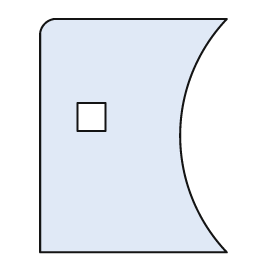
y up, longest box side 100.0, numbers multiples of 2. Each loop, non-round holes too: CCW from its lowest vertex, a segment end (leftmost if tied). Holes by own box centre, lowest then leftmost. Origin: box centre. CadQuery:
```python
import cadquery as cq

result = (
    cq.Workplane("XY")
    .moveTo(-40.0, -50.0)
    .lineTo(40.0, -50.0)
    .threePointArc((20.0, 0.0), (40.0, 50.0))
    .lineTo(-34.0, 50.0)
    .threePointArc((-38.0, 48.0), (-40.0, 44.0))
    .close()
    .moveTo(-24.0, 2.0)
    .lineTo(-12.0, 2.0)
    .lineTo(-12.0, 14.0)
    .lineTo(-24.0, 14.0)
    .close()
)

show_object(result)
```